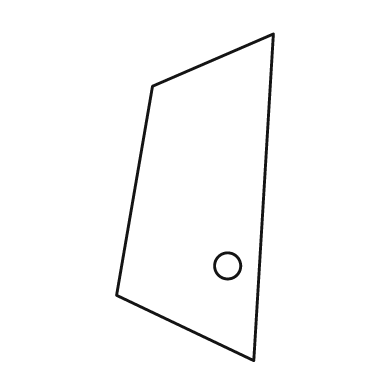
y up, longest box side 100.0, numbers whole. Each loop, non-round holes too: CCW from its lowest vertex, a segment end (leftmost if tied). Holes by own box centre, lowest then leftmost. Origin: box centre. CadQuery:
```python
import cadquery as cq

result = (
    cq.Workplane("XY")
    .moveTo(18.0, -50.0)
    .lineTo(24.0, 50.0)
    .lineTo(-13.0, 34.0)
    .lineTo(-24.0, -30.0)
    .close()
    .moveTo(10.0, -21.0)
    .circle(4.0)
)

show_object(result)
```